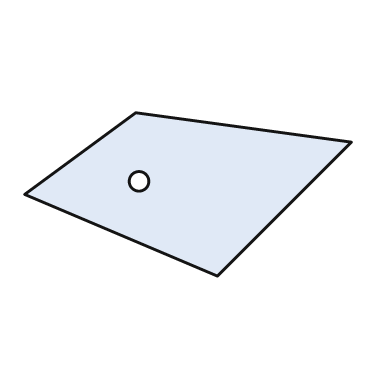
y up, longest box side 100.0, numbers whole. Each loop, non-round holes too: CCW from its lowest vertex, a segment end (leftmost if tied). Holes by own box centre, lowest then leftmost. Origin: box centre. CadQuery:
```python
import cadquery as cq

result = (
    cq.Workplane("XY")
    .moveTo(9.0, -25.0)
    .lineTo(50.0, 16.0)
    .lineTo(-16.0, 25.0)
    .lineTo(-50.0, 0.0)
    .close()
    .moveTo(-15.0, 4.0)
    .circle(3.0)
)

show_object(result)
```